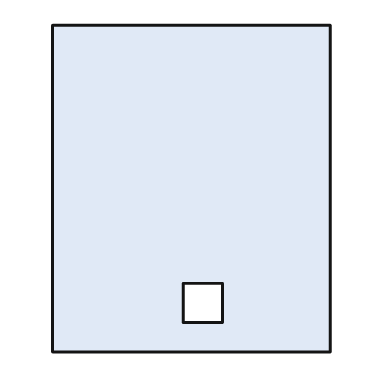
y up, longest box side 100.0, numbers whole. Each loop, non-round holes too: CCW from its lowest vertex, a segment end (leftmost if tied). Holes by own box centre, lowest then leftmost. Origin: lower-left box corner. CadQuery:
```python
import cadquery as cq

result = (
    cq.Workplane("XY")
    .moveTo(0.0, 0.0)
    .lineTo(85.0, 0.0)
    .lineTo(85.0, 100.0)
    .lineTo(0.0, 100.0)
    .close()
    .moveTo(40.0, 9.0)
    .lineTo(52.0, 9.0)
    .lineTo(52.0, 21.0)
    .lineTo(40.0, 21.0)
    .close()
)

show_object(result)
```